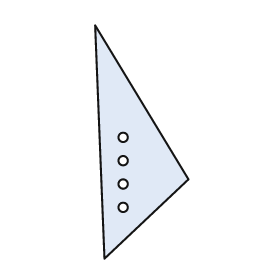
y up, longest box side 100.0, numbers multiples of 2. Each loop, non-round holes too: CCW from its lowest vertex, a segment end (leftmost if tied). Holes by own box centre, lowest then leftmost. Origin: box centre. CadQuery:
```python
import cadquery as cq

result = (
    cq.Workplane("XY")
    .moveTo(-16.0, -50.0)
    .lineTo(20.0, -16.0)
    .lineTo(-20.0, 50.0)
    .close()
    .moveTo(-8.0, -28.0)
    .circle(2.0)
    .moveTo(-8.0, -18.0)
    .circle(2.0)
    .moveTo(-8.0, -8.0)
    .circle(2.0)
    .moveTo(-8.0, 2.0)
    .circle(2.0)
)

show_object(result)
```